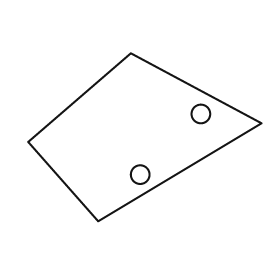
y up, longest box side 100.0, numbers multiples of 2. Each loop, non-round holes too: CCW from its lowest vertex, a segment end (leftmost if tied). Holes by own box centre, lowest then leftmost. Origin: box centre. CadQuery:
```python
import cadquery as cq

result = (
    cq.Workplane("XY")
    .moveTo(-20.0, -36.0)
    .lineTo(50.0, 6.0)
    .lineTo(-6.0, 36.0)
    .lineTo(-50.0, -2.0)
    .close()
    .moveTo(-2.0, -16.0)
    .circle(4.0)
    .moveTo(24.0, 10.0)
    .circle(4.0)
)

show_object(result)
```